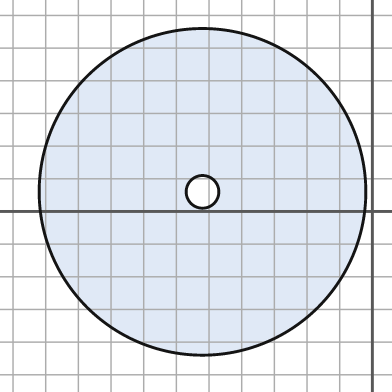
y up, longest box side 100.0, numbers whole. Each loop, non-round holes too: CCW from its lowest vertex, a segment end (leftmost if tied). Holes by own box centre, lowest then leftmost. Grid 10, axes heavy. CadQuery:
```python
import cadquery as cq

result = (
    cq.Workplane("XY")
    .moveTo(-52.0, 6.0)
    .circle(50.0)
    .moveTo(-52.0, 6.0)
    .circle(5.0)
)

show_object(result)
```